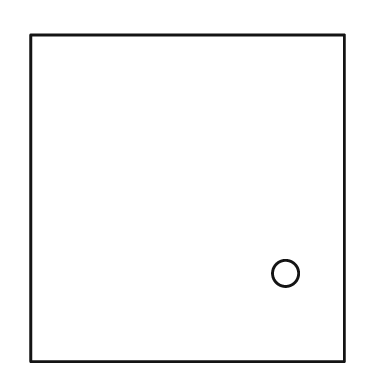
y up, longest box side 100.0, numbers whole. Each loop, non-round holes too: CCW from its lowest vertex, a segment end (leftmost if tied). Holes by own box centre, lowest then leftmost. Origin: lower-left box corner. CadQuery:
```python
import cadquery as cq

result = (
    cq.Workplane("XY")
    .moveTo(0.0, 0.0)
    .lineTo(96.0, 0.0)
    .lineTo(96.0, 100.0)
    .lineTo(0.0, 100.0)
    .close()
    .moveTo(78.0, 27.0)
    .circle(4.0)
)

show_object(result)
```